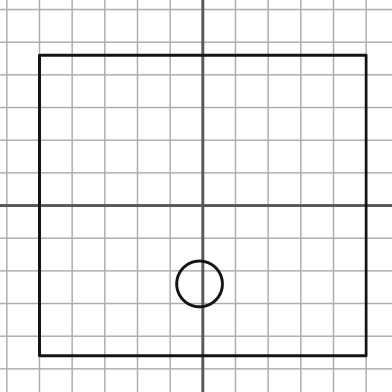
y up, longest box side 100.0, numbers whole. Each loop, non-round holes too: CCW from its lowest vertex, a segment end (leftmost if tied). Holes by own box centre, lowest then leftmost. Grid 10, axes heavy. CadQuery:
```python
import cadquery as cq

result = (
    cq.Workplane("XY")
    .moveTo(-50.0, -46.0)
    .lineTo(50.0, -46.0)
    .lineTo(50.0, 46.0)
    .lineTo(-50.0, 46.0)
    .close()
    .moveTo(-1.0, -24.0)
    .circle(7.0)
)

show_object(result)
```